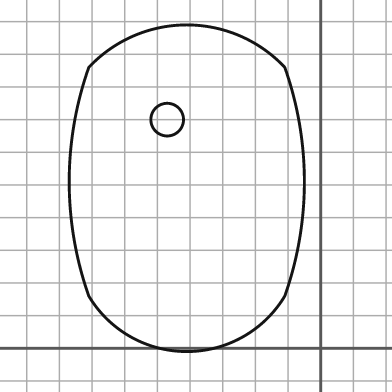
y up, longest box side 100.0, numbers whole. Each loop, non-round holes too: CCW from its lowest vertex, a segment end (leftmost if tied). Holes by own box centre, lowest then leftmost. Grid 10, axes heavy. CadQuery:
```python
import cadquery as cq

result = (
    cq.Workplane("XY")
    .moveTo(-71.0, 16.0)
    .threePointArc((-41.0, -1.0), (-11.0, 16.0))
    .threePointArc((-5.0, 51.0), (-11.0, 86.0))
    .threePointArc((-41.0, 99.0), (-71.0, 86.0))
    .threePointArc((-77.0, 51.0), (-71.0, 16.0))
    .close()
    .moveTo(-47.0, 70.0)
    .circle(5.0)
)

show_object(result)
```